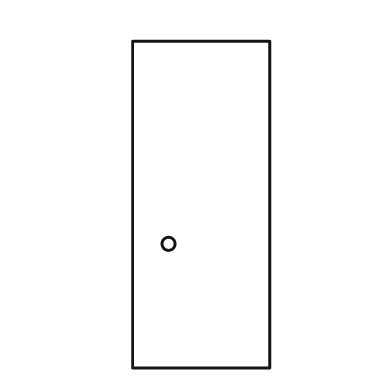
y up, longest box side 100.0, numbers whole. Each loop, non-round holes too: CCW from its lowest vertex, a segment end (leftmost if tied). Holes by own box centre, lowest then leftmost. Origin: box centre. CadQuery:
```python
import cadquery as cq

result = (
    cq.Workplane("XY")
    .moveTo(-21.0, -50.0)
    .lineTo(21.0, -50.0)
    .lineTo(21.0, 50.0)
    .lineTo(-21.0, 50.0)
    .close()
    .moveTo(-10.0, -12.0)
    .circle(2.0)
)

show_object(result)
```